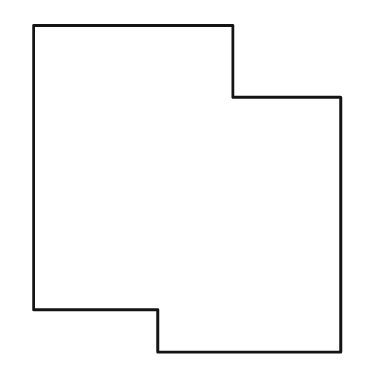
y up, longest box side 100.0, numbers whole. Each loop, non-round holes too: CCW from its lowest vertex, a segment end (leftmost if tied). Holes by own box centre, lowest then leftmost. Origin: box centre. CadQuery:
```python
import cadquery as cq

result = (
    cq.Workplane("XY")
    .moveTo(-9.0, -50.0)
    .lineTo(47.0, -50.0)
    .lineTo(47.0, 28.0)
    .lineTo(14.0, 28.0)
    .lineTo(14.0, 50.0)
    .lineTo(-47.0, 50.0)
    .lineTo(-47.0, -37.0)
    .lineTo(-9.0, -37.0)
    .close()
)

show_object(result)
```